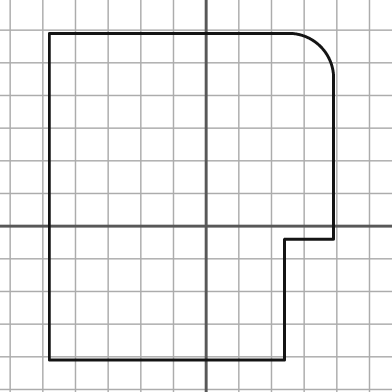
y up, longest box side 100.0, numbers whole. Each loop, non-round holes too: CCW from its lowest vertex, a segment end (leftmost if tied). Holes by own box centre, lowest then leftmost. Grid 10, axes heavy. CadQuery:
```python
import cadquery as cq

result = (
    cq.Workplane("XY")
    .moveTo(-48.0, -41.0)
    .lineTo(24.0, -41.0)
    .lineTo(24.0, -4.0)
    .lineTo(39.0, -4.0)
    .lineTo(39.0, 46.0)
    .threePointArc((35.0, 55.0), (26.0, 59.0))
    .lineTo(-48.0, 59.0)
    .close()
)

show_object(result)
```